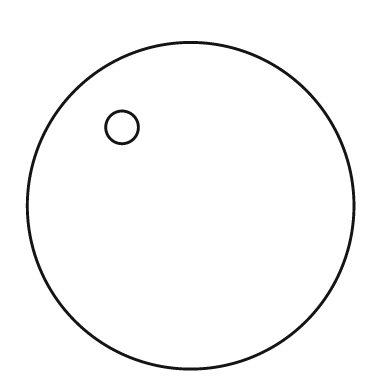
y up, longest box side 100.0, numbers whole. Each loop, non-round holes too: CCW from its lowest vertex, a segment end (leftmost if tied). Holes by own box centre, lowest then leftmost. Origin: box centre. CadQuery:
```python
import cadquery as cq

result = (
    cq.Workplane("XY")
    .moveTo(0.0, 0.0)
    .circle(50.0)
    .moveTo(-21.0, 24.0)
    .circle(5.0)
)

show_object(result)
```